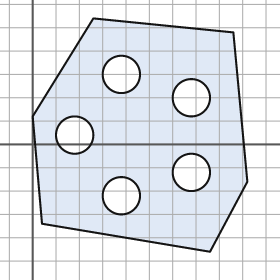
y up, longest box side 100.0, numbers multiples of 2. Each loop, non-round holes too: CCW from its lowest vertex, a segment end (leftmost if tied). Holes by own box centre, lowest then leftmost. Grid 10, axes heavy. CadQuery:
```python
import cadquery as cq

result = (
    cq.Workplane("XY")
    .moveTo(76.0, -46.0)
    .lineTo(92.0, -16.0)
    .lineTo(86.0, 48.0)
    .lineTo(26.0, 54.0)
    .lineTo(0.0, 12.0)
    .lineTo(4.0, -34.0)
    .close()
    .moveTo(38.0, -22.0)
    .circle(8.0)
    .moveTo(68.0, -12.0)
    .circle(8.0)
    .moveTo(18.0, 4.0)
    .circle(8.0)
    .moveTo(68.0, 20.0)
    .circle(8.0)
    .moveTo(38.0, 30.0)
    .circle(8.0)
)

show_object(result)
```